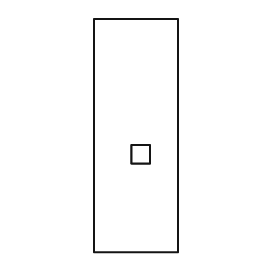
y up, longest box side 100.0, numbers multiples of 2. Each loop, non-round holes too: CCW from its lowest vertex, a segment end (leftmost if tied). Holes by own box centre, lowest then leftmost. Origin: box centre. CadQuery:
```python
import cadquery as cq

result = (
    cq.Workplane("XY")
    .moveTo(-18.0, -50.0)
    .lineTo(18.0, -50.0)
    .lineTo(18.0, 50.0)
    .lineTo(-18.0, 50.0)
    .close()
    .moveTo(-2.0, -12.0)
    .lineTo(6.0, -12.0)
    .lineTo(6.0, -4.0)
    .lineTo(-2.0, -4.0)
    .close()
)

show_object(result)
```